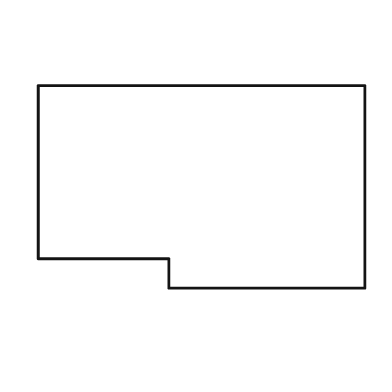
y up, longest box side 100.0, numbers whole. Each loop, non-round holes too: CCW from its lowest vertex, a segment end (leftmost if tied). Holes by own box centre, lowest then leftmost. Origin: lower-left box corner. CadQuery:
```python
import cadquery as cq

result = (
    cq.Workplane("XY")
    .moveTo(40.0, 0.0)
    .lineTo(100.0, 0.0)
    .lineTo(100.0, 62.0)
    .lineTo(0.0, 62.0)
    .lineTo(0.0, 9.0)
    .lineTo(40.0, 9.0)
    .close()
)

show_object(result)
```